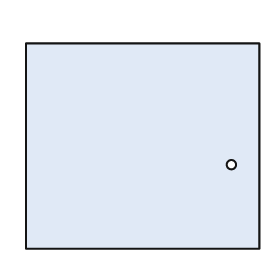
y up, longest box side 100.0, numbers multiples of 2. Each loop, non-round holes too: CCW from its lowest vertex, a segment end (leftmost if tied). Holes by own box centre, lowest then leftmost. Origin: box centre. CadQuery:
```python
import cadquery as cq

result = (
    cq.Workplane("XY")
    .moveTo(-50.0, -44.0)
    .lineTo(50.0, -44.0)
    .lineTo(50.0, 44.0)
    .lineTo(-50.0, 44.0)
    .close()
    .moveTo(38.0, -8.0)
    .circle(2.0)
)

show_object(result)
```